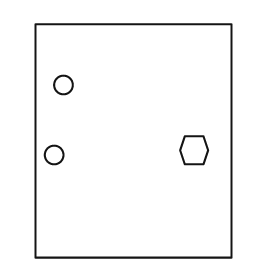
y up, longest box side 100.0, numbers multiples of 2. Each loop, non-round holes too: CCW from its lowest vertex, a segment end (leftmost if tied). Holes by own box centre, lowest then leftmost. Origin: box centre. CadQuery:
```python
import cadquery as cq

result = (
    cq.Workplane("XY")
    .moveTo(-42.0, -50.0)
    .lineTo(42.0, -50.0)
    .lineTo(42.0, 50.0)
    .lineTo(-42.0, 50.0)
    .close()
    .moveTo(-34.0, -6.0)
    .circle(4.0)
    .moveTo(22.0, -10.0)
    .lineTo(30.0, -10.0)
    .lineTo(32.0, -4.0)
    .lineTo(30.0, 2.0)
    .lineTo(22.0, 2.0)
    .lineTo(20.0, -4.0)
    .close()
    .moveTo(-30.0, 24.0)
    .circle(4.0)
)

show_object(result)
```